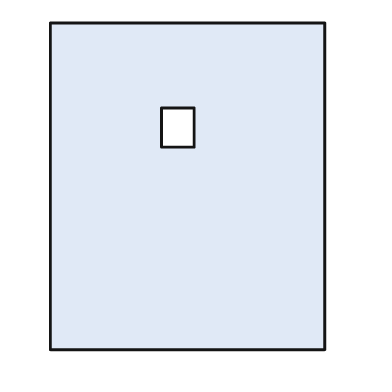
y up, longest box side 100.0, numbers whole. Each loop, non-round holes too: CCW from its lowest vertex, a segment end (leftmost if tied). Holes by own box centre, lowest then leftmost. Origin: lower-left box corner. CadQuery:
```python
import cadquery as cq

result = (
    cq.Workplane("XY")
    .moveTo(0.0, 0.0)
    .lineTo(84.0, 0.0)
    .lineTo(84.0, 100.0)
    .lineTo(0.0, 100.0)
    .close()
    .moveTo(34.0, 62.0)
    .lineTo(44.0, 62.0)
    .lineTo(44.0, 74.0)
    .lineTo(34.0, 74.0)
    .close()
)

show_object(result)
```